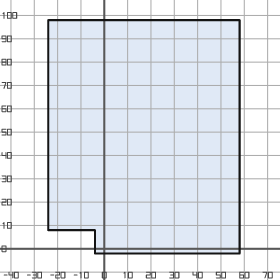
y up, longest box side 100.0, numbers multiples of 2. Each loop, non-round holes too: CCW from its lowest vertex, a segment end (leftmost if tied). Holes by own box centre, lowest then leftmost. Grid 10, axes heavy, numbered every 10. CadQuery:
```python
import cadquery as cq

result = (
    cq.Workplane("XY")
    .moveTo(-4.0, -2.0)
    .lineTo(58.0, -2.0)
    .lineTo(58.0, 98.0)
    .lineTo(-24.0, 98.0)
    .lineTo(-24.0, 8.0)
    .lineTo(-4.0, 8.0)
    .close()
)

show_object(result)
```